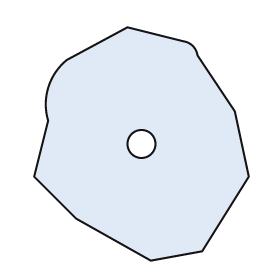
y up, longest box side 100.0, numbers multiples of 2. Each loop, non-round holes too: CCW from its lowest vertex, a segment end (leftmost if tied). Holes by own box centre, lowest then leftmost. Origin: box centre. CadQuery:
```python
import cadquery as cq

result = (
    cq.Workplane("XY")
    .moveTo(4.0, -50.0)
    .lineTo(26.0, -46.0)
    .lineTo(46.0, -14.0)
    .lineTo(40.0, 14.0)
    .lineTo(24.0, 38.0)
    .threePointArc((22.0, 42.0), (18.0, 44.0))
    .lineTo(-6.0, 50.0)
    .lineTo(-32.0, 36.0)
    .threePointArc((-40.0, 24.0), (-40.0, 10.0))
    .lineTo(-46.0, -14.0)
    .lineTo(-28.0, -32.0)
    .close()
    .moveTo(0.0, 0.0)
    .circle(6.0)
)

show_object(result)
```